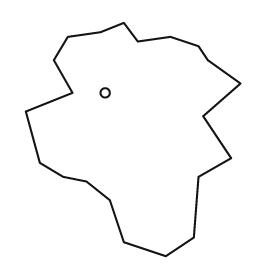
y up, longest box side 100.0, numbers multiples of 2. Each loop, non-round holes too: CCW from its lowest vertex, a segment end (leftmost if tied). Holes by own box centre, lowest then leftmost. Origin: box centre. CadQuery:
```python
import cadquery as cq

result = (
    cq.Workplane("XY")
    .moveTo(14.0, -50.0)
    .lineTo(26.0, -42.0)
    .lineTo(28.0, -16.0)
    .lineTo(42.0, -8.0)
    .lineTo(30.0, 10.0)
    .lineTo(46.0, 24.0)
    .lineTo(32.0, 34.0)
    .lineTo(28.0, 40.0)
    .lineTo(16.0, 44.0)
    .lineTo(2.0, 42.0)
    .lineTo(-4.0, 50.0)
    .lineTo(-14.0, 46.0)
    .lineTo(-28.0, 44.0)
    .lineTo(-34.0, 34.0)
    .lineTo(-26.0, 20.0)
    .lineTo(-46.0, 12.0)
    .lineTo(-40.0, -10.0)
    .lineTo(-30.0, -16.0)
    .lineTo(-20.0, -18.0)
    .lineTo(-10.0, -26.0)
    .lineTo(-4.0, -44.0)
    .close()
    .moveTo(-12.0, 20.0)
    .circle(2.0)
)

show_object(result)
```